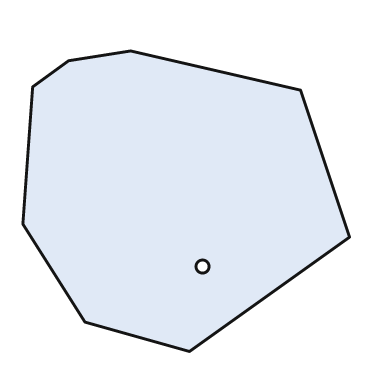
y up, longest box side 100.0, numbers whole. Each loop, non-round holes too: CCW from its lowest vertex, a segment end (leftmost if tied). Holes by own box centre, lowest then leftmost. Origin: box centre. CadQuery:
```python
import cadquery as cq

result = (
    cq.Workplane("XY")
    .moveTo(1.0, -46.0)
    .lineTo(50.0, -11.0)
    .lineTo(35.0, 34.0)
    .lineTo(-17.0, 46.0)
    .lineTo(-36.0, 43.0)
    .lineTo(-47.0, 35.0)
    .lineTo(-50.0, -7.0)
    .lineTo(-31.0, -37.0)
    .close()
    .moveTo(5.0, -20.0)
    .circle(2.0)
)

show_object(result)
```